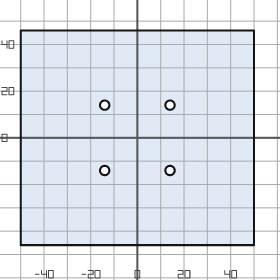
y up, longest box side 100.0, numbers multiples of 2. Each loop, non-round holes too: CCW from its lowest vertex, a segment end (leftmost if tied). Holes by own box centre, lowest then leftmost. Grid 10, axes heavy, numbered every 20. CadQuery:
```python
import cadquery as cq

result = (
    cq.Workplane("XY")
    .moveTo(-50.0, -46.0)
    .lineTo(50.0, -46.0)
    .lineTo(50.0, 46.0)
    .lineTo(-50.0, 46.0)
    .close()
    .moveTo(-14.0, -14.0)
    .circle(2.0)
    .moveTo(14.0, -14.0)
    .circle(2.0)
    .moveTo(-14.0, 14.0)
    .circle(2.0)
    .moveTo(14.0, 14.0)
    .circle(2.0)
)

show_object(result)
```